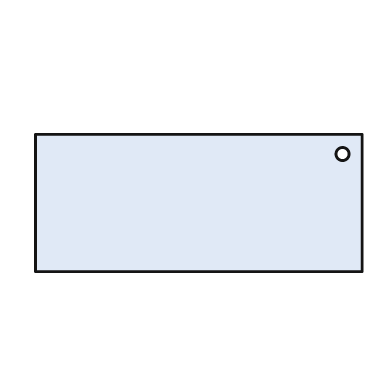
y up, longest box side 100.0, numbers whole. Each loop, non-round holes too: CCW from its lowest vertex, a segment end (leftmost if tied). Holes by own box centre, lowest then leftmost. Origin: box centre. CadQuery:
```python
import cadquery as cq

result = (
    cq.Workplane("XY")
    .moveTo(-50.0, -21.0)
    .lineTo(50.0, -21.0)
    .lineTo(50.0, 21.0)
    .lineTo(-50.0, 21.0)
    .close()
    .moveTo(44.0, 15.0)
    .circle(2.0)
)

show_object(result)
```